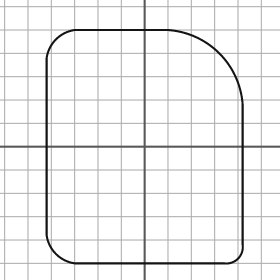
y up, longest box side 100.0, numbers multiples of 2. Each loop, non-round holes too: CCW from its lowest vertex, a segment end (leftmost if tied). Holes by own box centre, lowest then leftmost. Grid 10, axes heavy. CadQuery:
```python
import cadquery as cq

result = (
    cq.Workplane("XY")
    .moveTo(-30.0, -50.0)
    .lineTo(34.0, -50.0)
    .threePointArc((40.0, -48.0), (42.0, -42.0))
    .lineTo(42.0, 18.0)
    .threePointArc((32.0, 40.0), (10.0, 50.0))
    .lineTo(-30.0, 50.0)
    .threePointArc((-38.0, 46.0), (-42.0, 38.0))
    .lineTo(-42.0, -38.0)
    .threePointArc((-38.0, -46.0), (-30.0, -50.0))
    .close()
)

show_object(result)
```